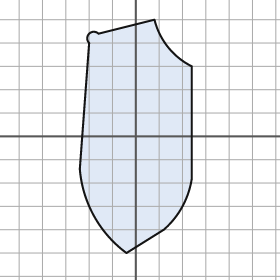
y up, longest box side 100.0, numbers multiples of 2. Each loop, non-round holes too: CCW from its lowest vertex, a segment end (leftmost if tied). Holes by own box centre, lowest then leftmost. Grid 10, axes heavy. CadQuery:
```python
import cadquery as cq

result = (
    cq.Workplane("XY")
    .moveTo(-4.0, -50.0)
    .lineTo(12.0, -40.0)
    .threePointArc((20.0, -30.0), (24.0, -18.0))
    .lineTo(24.0, 30.0)
    .threePointArc((14.0, 38.0), (8.0, 50.0))
    .lineTo(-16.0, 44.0)
    .threePointArc((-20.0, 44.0), (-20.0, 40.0))
    .lineTo(-24.0, -14.0)
    .threePointArc((-18.0, -34.0), (-4.0, -50.0))
    .close()
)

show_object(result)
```